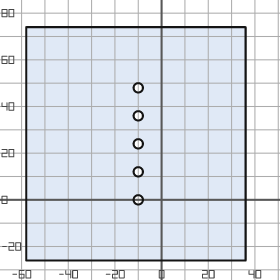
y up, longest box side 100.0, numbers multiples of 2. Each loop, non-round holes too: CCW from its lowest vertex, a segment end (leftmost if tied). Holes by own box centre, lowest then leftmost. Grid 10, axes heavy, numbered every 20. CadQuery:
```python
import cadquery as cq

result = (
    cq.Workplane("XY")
    .moveTo(-58.0, -26.0)
    .lineTo(36.0, -26.0)
    .lineTo(36.0, 74.0)
    .lineTo(-58.0, 74.0)
    .close()
    .moveTo(-10.0, 0.0)
    .circle(2.0)
    .moveTo(-10.0, 12.0)
    .circle(2.0)
    .moveTo(-10.0, 24.0)
    .circle(2.0)
    .moveTo(-10.0, 36.0)
    .circle(2.0)
    .moveTo(-10.0, 48.0)
    .circle(2.0)
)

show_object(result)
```